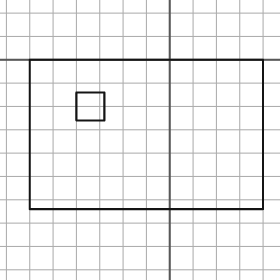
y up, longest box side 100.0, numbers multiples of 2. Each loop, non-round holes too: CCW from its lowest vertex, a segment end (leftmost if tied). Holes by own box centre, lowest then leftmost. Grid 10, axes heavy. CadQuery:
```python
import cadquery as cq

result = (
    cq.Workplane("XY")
    .moveTo(-60.0, -64.0)
    .lineTo(40.0, -64.0)
    .lineTo(40.0, 0.0)
    .lineTo(-60.0, 0.0)
    .close()
    .moveTo(-40.0, -26.0)
    .lineTo(-28.0, -26.0)
    .lineTo(-28.0, -14.0)
    .lineTo(-40.0, -14.0)
    .close()
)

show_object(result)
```